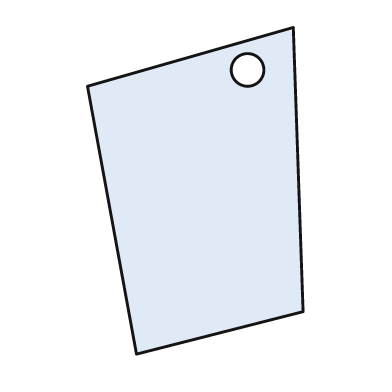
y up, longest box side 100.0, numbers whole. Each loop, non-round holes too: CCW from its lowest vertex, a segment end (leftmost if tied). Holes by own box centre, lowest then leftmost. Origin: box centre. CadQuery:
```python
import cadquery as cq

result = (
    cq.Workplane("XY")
    .moveTo(-18.0, -50.0)
    .lineTo(33.0, -37.0)
    .lineTo(30.0, 50.0)
    .lineTo(-33.0, 32.0)
    .close()
    .moveTo(16.0, 37.0)
    .circle(5.0)
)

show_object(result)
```